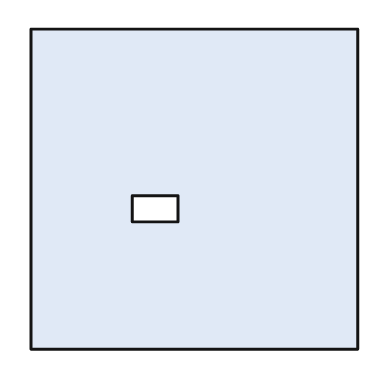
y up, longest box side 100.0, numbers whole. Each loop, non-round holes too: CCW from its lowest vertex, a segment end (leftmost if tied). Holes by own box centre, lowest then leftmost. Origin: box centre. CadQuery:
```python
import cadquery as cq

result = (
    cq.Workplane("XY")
    .moveTo(-50.0, -49.0)
    .lineTo(50.0, -49.0)
    .lineTo(50.0, 49.0)
    .lineTo(-50.0, 49.0)
    .close()
    .moveTo(-19.0, -10.0)
    .lineTo(-5.0, -10.0)
    .lineTo(-5.0, -2.0)
    .lineTo(-19.0, -2.0)
    .close()
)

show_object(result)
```